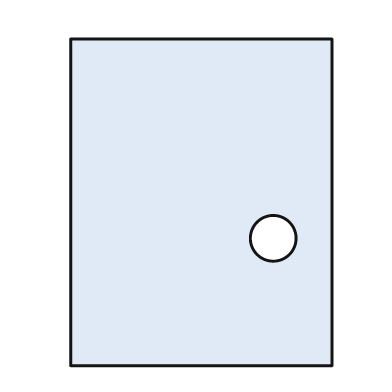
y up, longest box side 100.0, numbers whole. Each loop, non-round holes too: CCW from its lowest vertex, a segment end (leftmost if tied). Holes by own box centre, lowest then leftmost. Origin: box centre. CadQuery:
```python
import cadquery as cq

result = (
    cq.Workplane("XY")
    .moveTo(-40.0, -50.0)
    .lineTo(40.0, -50.0)
    .lineTo(40.0, 50.0)
    .lineTo(-40.0, 50.0)
    .close()
    .moveTo(22.0, -11.0)
    .circle(7.0)
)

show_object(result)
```